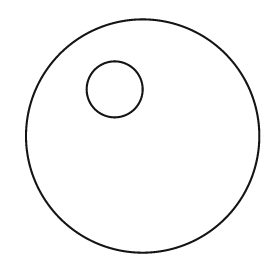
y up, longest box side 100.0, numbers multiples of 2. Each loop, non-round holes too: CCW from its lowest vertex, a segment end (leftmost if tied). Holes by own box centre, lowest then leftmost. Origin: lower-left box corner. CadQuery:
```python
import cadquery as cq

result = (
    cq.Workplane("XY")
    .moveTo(50.0, 50.0)
    .circle(50.0)
    .moveTo(38.0, 70.0)
    .circle(12.0)
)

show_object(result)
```